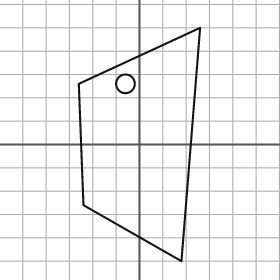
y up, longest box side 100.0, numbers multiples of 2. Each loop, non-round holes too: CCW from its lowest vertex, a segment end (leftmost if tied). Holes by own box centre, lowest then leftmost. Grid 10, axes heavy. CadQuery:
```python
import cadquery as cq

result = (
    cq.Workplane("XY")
    .moveTo(18.0, -50.0)
    .lineTo(26.0, 50.0)
    .lineTo(-26.0, 26.0)
    .lineTo(-24.0, -26.0)
    .close()
    .moveTo(-6.0, 26.0)
    .circle(4.0)
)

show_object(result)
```